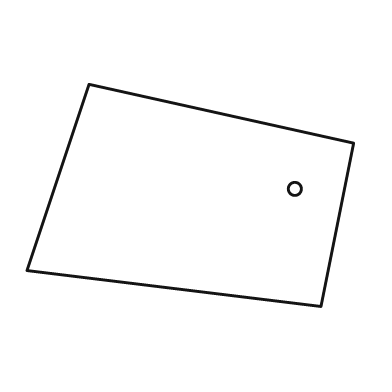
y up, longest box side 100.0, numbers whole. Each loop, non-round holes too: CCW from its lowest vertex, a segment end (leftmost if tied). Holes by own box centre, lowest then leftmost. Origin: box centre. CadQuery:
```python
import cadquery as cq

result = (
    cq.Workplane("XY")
    .moveTo(40.0, -34.0)
    .lineTo(50.0, 16.0)
    .lineTo(-31.0, 34.0)
    .lineTo(-50.0, -23.0)
    .close()
    .moveTo(32.0, 2.0)
    .circle(2.0)
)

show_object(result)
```